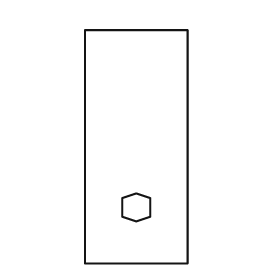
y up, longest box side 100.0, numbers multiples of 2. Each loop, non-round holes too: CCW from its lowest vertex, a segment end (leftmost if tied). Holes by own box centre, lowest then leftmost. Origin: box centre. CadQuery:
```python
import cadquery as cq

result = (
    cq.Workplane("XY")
    .moveTo(-22.0, -50.0)
    .lineTo(22.0, -50.0)
    .lineTo(22.0, 50.0)
    .lineTo(-22.0, 50.0)
    .close()
    .moveTo(0.0, -32.0)
    .lineTo(6.0, -30.0)
    .lineTo(6.0, -22.0)
    .lineTo(0.0, -20.0)
    .lineTo(-6.0, -22.0)
    .lineTo(-6.0, -30.0)
    .close()
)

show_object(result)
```